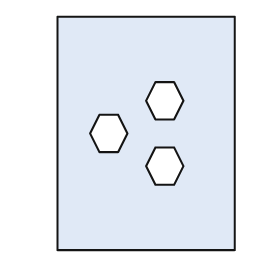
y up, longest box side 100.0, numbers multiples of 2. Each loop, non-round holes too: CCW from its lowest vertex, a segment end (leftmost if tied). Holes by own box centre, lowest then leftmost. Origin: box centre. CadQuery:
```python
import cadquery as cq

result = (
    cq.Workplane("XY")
    .moveTo(-38.0, -50.0)
    .lineTo(38.0, -50.0)
    .lineTo(38.0, 50.0)
    .lineTo(-38.0, 50.0)
    .close()
    .moveTo(4.0, -22.0)
    .lineTo(12.0, -22.0)
    .lineTo(16.0, -14.0)
    .lineTo(12.0, -6.0)
    .lineTo(4.0, -6.0)
    .lineTo(0.0, -14.0)
    .close()
    .moveTo(-20.0, -8.0)
    .lineTo(-12.0, -8.0)
    .lineTo(-8.0, 0.0)
    .lineTo(-12.0, 8.0)
    .lineTo(-20.0, 8.0)
    .lineTo(-24.0, 0.0)
    .close()
    .moveTo(4.0, 6.0)
    .lineTo(12.0, 6.0)
    .lineTo(16.0, 14.0)
    .lineTo(12.0, 22.0)
    .lineTo(4.0, 22.0)
    .lineTo(0.0, 14.0)
    .close()
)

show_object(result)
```